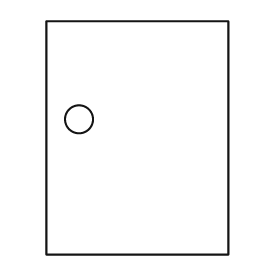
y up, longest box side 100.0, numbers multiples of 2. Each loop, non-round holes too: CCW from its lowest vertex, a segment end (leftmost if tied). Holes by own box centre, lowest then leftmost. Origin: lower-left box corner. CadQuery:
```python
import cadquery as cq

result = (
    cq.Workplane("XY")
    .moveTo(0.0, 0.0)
    .lineTo(78.0, 0.0)
    .lineTo(78.0, 100.0)
    .lineTo(0.0, 100.0)
    .close()
    .moveTo(14.0, 58.0)
    .circle(6.0)
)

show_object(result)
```